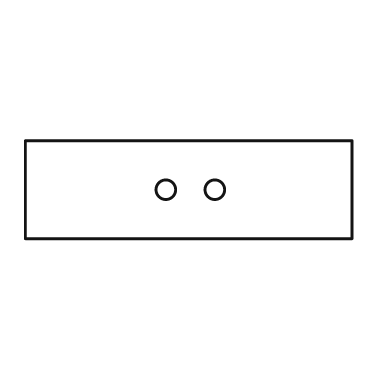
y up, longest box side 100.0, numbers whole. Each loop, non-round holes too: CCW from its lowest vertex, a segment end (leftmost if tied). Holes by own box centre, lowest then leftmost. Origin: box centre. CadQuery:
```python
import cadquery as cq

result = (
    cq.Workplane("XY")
    .moveTo(-50.0, -15.0)
    .lineTo(50.0, -15.0)
    .lineTo(50.0, 15.0)
    .lineTo(-50.0, 15.0)
    .close()
    .moveTo(-7.0, 0.0)
    .circle(3.0)
    .moveTo(8.0, 0.0)
    .circle(3.0)
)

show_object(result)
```